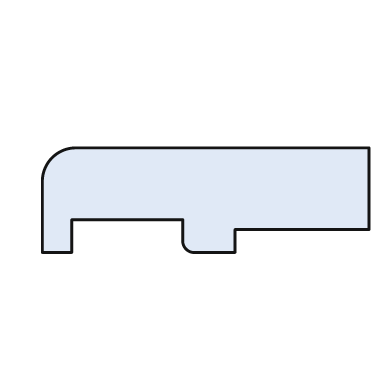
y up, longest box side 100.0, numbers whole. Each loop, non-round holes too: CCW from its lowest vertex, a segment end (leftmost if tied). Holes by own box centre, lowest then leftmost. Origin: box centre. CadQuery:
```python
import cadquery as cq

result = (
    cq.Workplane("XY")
    .moveTo(-50.0, -16.0)
    .lineTo(-41.0, -16.0)
    .lineTo(-41.0, -6.0)
    .lineTo(-7.0, -6.0)
    .lineTo(-7.0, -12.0)
    .threePointArc((-6.0, -15.0), (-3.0, -16.0))
    .lineTo(9.0, -16.0)
    .lineTo(9.0, -9.0)
    .lineTo(50.0, -9.0)
    .lineTo(50.0, 16.0)
    .lineTo(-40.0, 16.0)
    .threePointArc((-47.0, 13.0), (-50.0, 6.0))
    .close()
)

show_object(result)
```